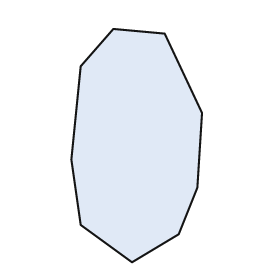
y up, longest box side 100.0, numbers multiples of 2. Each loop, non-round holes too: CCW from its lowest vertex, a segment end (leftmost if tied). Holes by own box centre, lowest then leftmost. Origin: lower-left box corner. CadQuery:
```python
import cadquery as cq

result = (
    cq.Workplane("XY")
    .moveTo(26.0, 0.0)
    .lineTo(46.0, 12.0)
    .lineTo(54.0, 32.0)
    .lineTo(56.0, 64.0)
    .lineTo(40.0, 98.0)
    .lineTo(18.0, 100.0)
    .lineTo(4.0, 84.0)
    .lineTo(0.0, 44.0)
    .lineTo(4.0, 16.0)
    .close()
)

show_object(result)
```